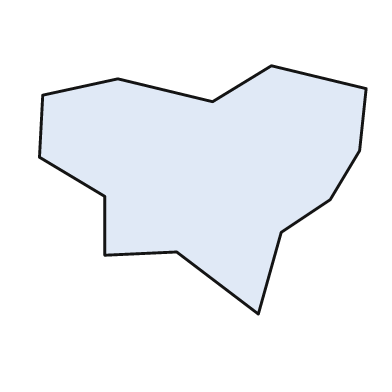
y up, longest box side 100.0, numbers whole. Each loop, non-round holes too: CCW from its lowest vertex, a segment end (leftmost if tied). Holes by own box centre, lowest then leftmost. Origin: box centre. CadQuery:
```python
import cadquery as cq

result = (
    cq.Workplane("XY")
    .moveTo(17.0, -38.0)
    .lineTo(24.0, -13.0)
    .lineTo(39.0, -3.0)
    .lineTo(48.0, 12.0)
    .lineTo(50.0, 31.0)
    .lineTo(21.0, 38.0)
    .lineTo(3.0, 27.0)
    .lineTo(-26.0, 34.0)
    .lineTo(-49.0, 29.0)
    .lineTo(-50.0, 10.0)
    .lineTo(-30.0, -2.0)
    .lineTo(-30.0, -20.0)
    .lineTo(-8.0, -19.0)
    .close()
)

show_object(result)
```